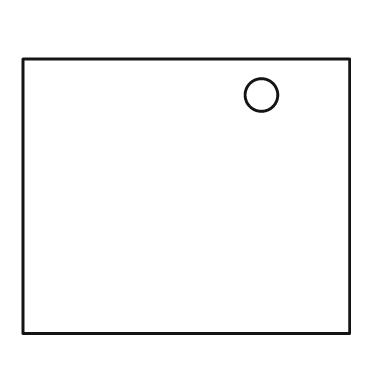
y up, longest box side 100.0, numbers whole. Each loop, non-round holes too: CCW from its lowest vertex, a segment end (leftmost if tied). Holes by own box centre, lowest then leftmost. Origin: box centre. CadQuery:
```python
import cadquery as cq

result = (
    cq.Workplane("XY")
    .moveTo(-50.0, -42.0)
    .lineTo(50.0, -42.0)
    .lineTo(50.0, 42.0)
    .lineTo(-50.0, 42.0)
    .close()
    .moveTo(23.0, 31.0)
    .circle(5.0)
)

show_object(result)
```